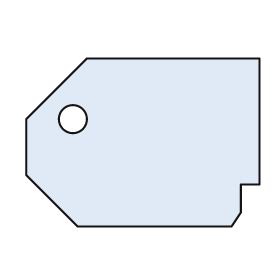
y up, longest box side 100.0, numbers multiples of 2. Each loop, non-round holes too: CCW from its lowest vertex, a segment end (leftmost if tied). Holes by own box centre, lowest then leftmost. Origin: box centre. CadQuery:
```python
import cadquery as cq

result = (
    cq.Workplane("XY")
    .moveTo(-28.0, -36.0)
    .lineTo(38.0, -36.0)
    .lineTo(42.0, -30.0)
    .lineTo(42.0, -18.0)
    .lineTo(50.0, -18.0)
    .lineTo(50.0, 36.0)
    .lineTo(-24.0, 36.0)
    .lineTo(-50.0, 10.0)
    .lineTo(-50.0, -14.0)
    .close()
    .moveTo(-30.0, 10.0)
    .circle(6.0)
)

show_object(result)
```